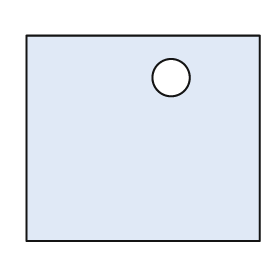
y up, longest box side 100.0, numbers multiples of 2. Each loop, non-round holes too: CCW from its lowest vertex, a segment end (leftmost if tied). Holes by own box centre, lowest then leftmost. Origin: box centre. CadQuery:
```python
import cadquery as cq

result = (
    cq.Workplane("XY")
    .moveTo(-50.0, -44.0)
    .lineTo(50.0, -44.0)
    .lineTo(50.0, 44.0)
    .lineTo(-50.0, 44.0)
    .close()
    .moveTo(12.0, 26.0)
    .circle(8.0)
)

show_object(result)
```